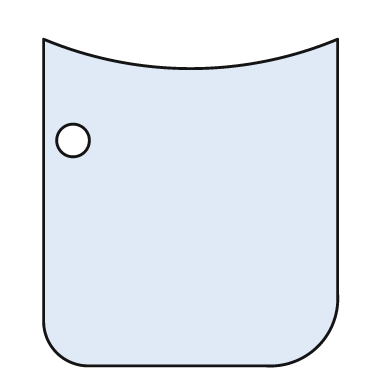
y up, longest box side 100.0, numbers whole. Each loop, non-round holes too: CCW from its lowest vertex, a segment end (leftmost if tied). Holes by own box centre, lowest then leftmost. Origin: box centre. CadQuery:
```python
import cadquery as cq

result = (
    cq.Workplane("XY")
    .moveTo(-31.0, -50.0)
    .lineTo(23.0, -50.0)
    .threePointArc((39.0, -44.0), (45.0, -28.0))
    .lineTo(45.0, 50.0)
    .threePointArc((0.0, 41.0), (-45.0, 50.0))
    .lineTo(-45.0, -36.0)
    .threePointArc((-41.0, -46.0), (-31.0, -50.0))
    .close()
    .moveTo(-36.0, 19.0)
    .circle(5.0)
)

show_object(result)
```